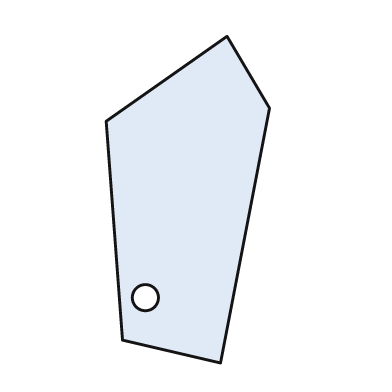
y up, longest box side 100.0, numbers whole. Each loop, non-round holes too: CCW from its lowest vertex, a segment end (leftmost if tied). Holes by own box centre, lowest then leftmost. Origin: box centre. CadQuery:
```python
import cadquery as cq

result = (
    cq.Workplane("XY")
    .moveTo(10.0, -50.0)
    .lineTo(25.0, 28.0)
    .lineTo(12.0, 50.0)
    .lineTo(-25.0, 24.0)
    .lineTo(-20.0, -43.0)
    .close()
    .moveTo(-13.0, -30.0)
    .circle(4.0)
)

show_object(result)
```